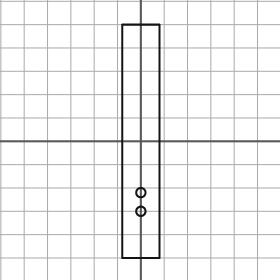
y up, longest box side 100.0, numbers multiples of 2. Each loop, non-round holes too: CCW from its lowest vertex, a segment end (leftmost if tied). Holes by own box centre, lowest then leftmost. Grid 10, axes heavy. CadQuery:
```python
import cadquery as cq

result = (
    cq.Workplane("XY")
    .moveTo(-8.0, -50.0)
    .lineTo(8.0, -50.0)
    .lineTo(8.0, 50.0)
    .lineTo(-8.0, 50.0)
    .close()
    .moveTo(0.0, -30.0)
    .circle(2.0)
    .moveTo(0.0, -22.0)
    .circle(2.0)
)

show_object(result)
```